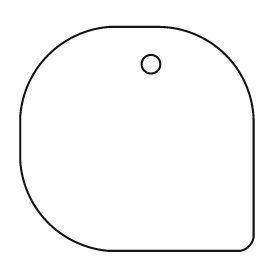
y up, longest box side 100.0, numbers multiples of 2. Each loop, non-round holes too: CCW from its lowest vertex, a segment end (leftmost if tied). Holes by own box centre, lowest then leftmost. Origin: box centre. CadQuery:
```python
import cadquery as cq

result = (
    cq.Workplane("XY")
    .moveTo(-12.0, -48.0)
    .lineTo(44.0, -48.0)
    .threePointArc((48.0, -46.0), (50.0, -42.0))
    .lineTo(50.0, 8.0)
    .threePointArc((38.0, 36.0), (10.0, 48.0))
    .lineTo(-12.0, 48.0)
    .threePointArc((-38.0, 36.0), (-50.0, 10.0))
    .lineTo(-50.0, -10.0)
    .threePointArc((-38.0, -36.0), (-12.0, -48.0))
    .close()
    .moveTo(6.0, 32.0)
    .circle(4.0)
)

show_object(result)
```